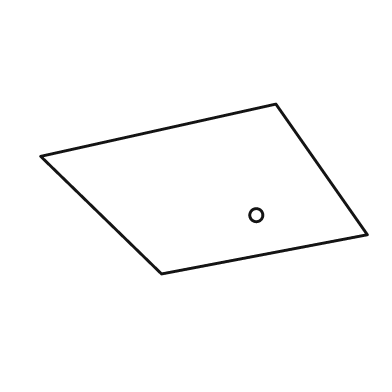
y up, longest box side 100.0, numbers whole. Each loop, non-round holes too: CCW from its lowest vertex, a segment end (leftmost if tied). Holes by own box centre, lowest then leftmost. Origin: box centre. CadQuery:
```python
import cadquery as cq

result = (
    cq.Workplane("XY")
    .moveTo(-13.0, -26.0)
    .lineTo(50.0, -14.0)
    .lineTo(22.0, 26.0)
    .lineTo(-50.0, 10.0)
    .close()
    .moveTo(16.0, -8.0)
    .circle(2.0)
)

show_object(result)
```